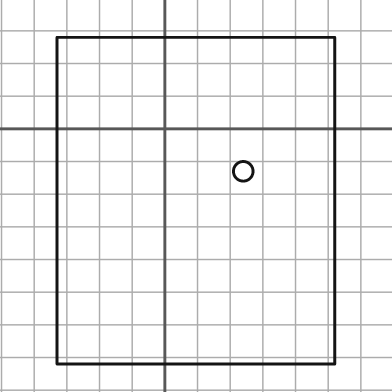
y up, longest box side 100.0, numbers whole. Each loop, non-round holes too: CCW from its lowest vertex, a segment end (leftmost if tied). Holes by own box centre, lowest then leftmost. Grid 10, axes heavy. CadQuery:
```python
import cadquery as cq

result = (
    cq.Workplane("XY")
    .moveTo(-33.0, -72.0)
    .lineTo(52.0, -72.0)
    .lineTo(52.0, 28.0)
    .lineTo(-33.0, 28.0)
    .close()
    .moveTo(24.0, -13.0)
    .circle(3.0)
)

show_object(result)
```